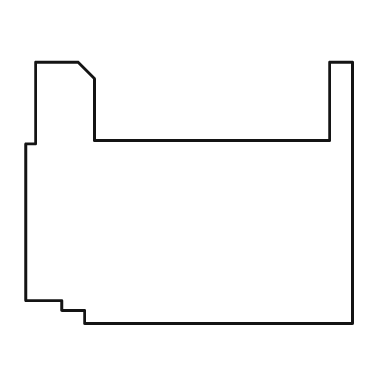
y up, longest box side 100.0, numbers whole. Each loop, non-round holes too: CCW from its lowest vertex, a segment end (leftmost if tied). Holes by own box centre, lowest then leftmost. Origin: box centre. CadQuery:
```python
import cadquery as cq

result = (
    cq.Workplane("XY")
    .moveTo(-32.0, -40.0)
    .lineTo(50.0, -40.0)
    .lineTo(50.0, 40.0)
    .lineTo(43.0, 40.0)
    .lineTo(43.0, 16.0)
    .lineTo(-29.0, 16.0)
    .lineTo(-29.0, 35.0)
    .lineTo(-34.0, 40.0)
    .lineTo(-47.0, 40.0)
    .lineTo(-47.0, 15.0)
    .lineTo(-50.0, 15.0)
    .lineTo(-50.0, -33.0)
    .lineTo(-39.0, -33.0)
    .lineTo(-39.0, -36.0)
    .lineTo(-32.0, -36.0)
    .close()
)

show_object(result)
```